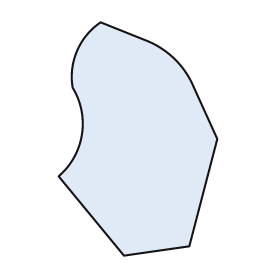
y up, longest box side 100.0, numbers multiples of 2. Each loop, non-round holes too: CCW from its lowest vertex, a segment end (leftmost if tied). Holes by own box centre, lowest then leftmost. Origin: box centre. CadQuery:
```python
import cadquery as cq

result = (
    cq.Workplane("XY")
    .moveTo(-6.0, -50.0)
    .lineTo(22.0, -46.0)
    .lineTo(34.0, 0.0)
    .lineTo(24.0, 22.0)
    .threePointArc((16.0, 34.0), (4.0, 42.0))
    .lineTo(-16.0, 50.0)
    .threePointArc((-26.0, 38.0), (-28.0, 22.0))
    .threePointArc((-24.0, 2.0), (-34.0, -16.0))
    .close()
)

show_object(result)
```